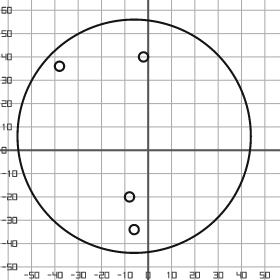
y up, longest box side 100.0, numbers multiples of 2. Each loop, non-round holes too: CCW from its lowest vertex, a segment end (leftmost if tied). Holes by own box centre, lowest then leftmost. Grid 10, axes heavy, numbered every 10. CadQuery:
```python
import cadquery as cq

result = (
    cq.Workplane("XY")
    .moveTo(-6.0, 6.0)
    .circle(50.0)
    .moveTo(-6.0, -34.0)
    .circle(2.0)
    .moveTo(-8.0, -20.0)
    .circle(2.0)
    .moveTo(-38.0, 36.0)
    .circle(2.0)
    .moveTo(-2.0, 40.0)
    .circle(2.0)
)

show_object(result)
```